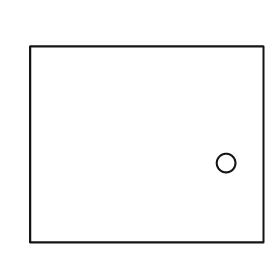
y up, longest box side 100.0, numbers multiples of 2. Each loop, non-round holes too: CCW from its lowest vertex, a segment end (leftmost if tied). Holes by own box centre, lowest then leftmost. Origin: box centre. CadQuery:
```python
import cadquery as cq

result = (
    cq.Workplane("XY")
    .moveTo(-50.0, -42.0)
    .lineTo(50.0, -42.0)
    .lineTo(50.0, 42.0)
    .lineTo(-50.0, 42.0)
    .close()
    .moveTo(34.0, -8.0)
    .circle(4.0)
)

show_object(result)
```